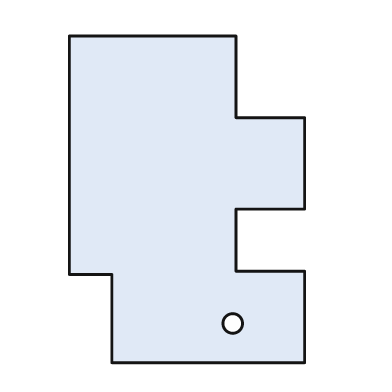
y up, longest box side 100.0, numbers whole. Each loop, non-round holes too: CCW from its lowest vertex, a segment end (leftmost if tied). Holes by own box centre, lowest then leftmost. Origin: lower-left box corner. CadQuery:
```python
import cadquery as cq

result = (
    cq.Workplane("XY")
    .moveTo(13.0, 0.0)
    .lineTo(72.0, 0.0)
    .lineTo(72.0, 28.0)
    .lineTo(51.0, 28.0)
    .lineTo(51.0, 47.0)
    .lineTo(72.0, 47.0)
    .lineTo(72.0, 75.0)
    .lineTo(51.0, 75.0)
    .lineTo(51.0, 100.0)
    .lineTo(0.0, 100.0)
    .lineTo(0.0, 27.0)
    .lineTo(13.0, 27.0)
    .close()
    .moveTo(50.0, 12.0)
    .circle(3.0)
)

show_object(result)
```